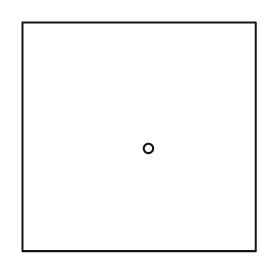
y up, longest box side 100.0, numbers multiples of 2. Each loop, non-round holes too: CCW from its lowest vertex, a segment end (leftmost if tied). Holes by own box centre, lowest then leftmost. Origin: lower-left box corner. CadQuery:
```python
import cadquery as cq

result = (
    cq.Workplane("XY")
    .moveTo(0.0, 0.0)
    .lineTo(100.0, 0.0)
    .lineTo(100.0, 98.0)
    .lineTo(0.0, 98.0)
    .close()
    .moveTo(54.0, 44.0)
    .circle(2.0)
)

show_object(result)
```